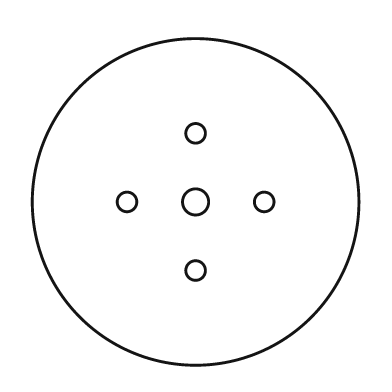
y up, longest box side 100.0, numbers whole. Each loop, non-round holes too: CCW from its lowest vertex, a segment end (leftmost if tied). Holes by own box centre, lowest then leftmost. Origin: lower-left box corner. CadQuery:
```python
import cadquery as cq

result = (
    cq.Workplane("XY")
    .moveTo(50.0, 50.0)
    .circle(50.0)
    .moveTo(50.0, 29.0)
    .circle(3.0)
    .moveTo(29.0, 50.0)
    .circle(3.0)
    .moveTo(50.0, 50.0)
    .circle(4.0)
    .moveTo(71.0, 50.0)
    .circle(3.0)
    .moveTo(50.0, 71.0)
    .circle(3.0)
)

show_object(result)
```